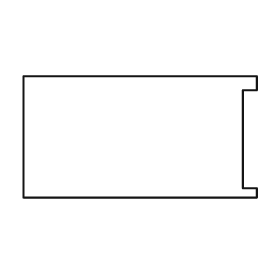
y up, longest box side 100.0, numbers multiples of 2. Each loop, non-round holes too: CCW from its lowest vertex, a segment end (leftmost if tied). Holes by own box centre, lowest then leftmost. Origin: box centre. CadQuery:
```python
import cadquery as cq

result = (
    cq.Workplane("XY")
    .moveTo(-50.0, -26.0)
    .lineTo(50.0, -26.0)
    .lineTo(50.0, -22.0)
    .lineTo(44.0, -22.0)
    .lineTo(44.0, 20.0)
    .lineTo(50.0, 20.0)
    .lineTo(50.0, 26.0)
    .lineTo(-50.0, 26.0)
    .close()
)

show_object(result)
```